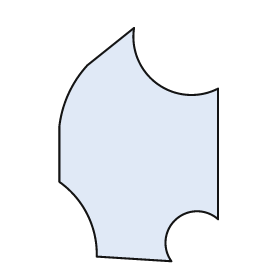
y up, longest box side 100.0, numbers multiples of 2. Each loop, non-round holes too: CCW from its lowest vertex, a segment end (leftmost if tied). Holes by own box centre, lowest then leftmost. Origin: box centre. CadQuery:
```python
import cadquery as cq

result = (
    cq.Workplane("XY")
    .moveTo(14.0, -50.0)
    .threePointArc((16.0, -32.0), (34.0, -32.0))
    .lineTo(34.0, 24.0)
    .threePointArc((8.0, 26.0), (-2.0, 50.0))
    .lineTo(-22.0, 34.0)
    .threePointArc((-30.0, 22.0), (-34.0, 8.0))
    .lineTo(-34.0, -16.0)
    .threePointArc((-22.0, -30.0), (-18.0, -48.0))
    .close()
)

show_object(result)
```